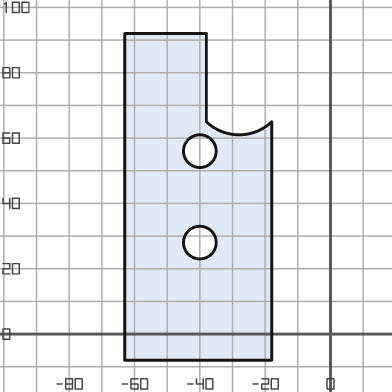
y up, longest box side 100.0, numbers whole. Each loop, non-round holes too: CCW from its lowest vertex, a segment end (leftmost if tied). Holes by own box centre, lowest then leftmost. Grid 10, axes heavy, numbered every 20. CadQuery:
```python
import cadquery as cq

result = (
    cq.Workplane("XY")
    .moveTo(-63.0, -8.0)
    .lineTo(-18.0, -8.0)
    .lineTo(-18.0, 65.0)
    .threePointArc((-28.0, 61.0), (-38.0, 65.0))
    .lineTo(-38.0, 92.0)
    .lineTo(-63.0, 92.0)
    .close()
    .moveTo(-40.0, 28.0)
    .circle(5.0)
    .moveTo(-40.0, 56.0)
    .circle(5.0)
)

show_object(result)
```